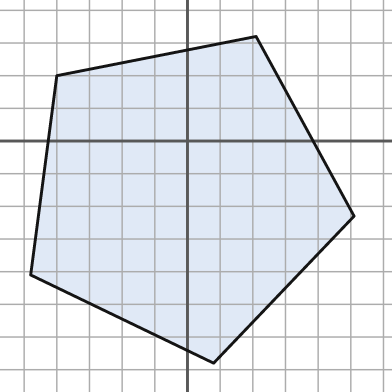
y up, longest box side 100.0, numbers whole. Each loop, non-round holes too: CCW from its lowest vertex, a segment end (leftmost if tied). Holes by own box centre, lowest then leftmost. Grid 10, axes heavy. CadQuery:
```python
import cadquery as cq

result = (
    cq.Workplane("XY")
    .moveTo(8.0, -68.0)
    .lineTo(51.0, -23.0)
    .lineTo(21.0, 32.0)
    .lineTo(-40.0, 20.0)
    .lineTo(-48.0, -41.0)
    .close()
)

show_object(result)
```